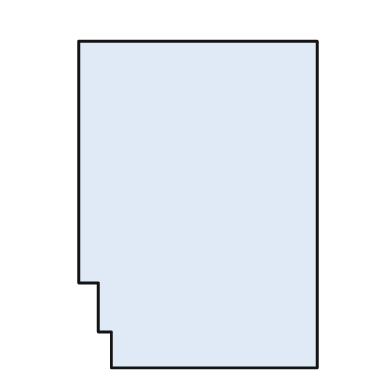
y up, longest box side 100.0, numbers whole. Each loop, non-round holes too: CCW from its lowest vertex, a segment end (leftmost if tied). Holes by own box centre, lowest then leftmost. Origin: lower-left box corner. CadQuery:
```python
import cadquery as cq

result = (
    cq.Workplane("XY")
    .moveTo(10.0, 0.0)
    .lineTo(73.0, 0.0)
    .lineTo(73.0, 100.0)
    .lineTo(0.0, 100.0)
    .lineTo(0.0, 26.0)
    .lineTo(6.0, 26.0)
    .lineTo(6.0, 11.0)
    .lineTo(10.0, 11.0)
    .close()
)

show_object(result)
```